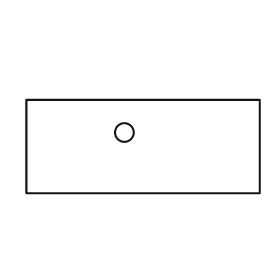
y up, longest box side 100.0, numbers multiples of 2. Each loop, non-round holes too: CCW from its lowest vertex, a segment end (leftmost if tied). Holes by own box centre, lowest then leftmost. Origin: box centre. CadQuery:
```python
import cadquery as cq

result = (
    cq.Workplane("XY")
    .moveTo(-50.0, -20.0)
    .lineTo(50.0, -20.0)
    .lineTo(50.0, 20.0)
    .lineTo(-50.0, 20.0)
    .close()
    .moveTo(-8.0, 6.0)
    .circle(4.0)
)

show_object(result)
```